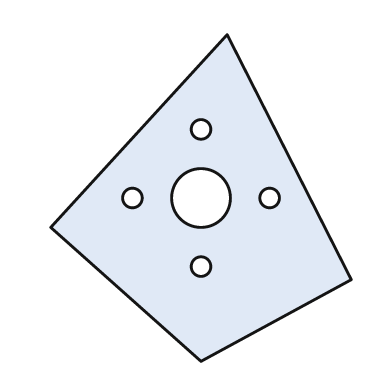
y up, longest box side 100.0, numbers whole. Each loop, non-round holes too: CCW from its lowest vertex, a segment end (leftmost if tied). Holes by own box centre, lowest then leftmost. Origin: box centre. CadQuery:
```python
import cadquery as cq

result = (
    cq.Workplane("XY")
    .moveTo(0.0, -50.0)
    .lineTo(46.0, -25.0)
    .lineTo(8.0, 50.0)
    .lineTo(-46.0, -9.0)
    .close()
    .moveTo(0.0, -21.0)
    .circle(3.0)
    .moveTo(-21.0, 0.0)
    .circle(3.0)
    .moveTo(0.0, 0.0)
    .circle(9.0)
    .moveTo(21.0, 0.0)
    .circle(3.0)
    .moveTo(0.0, 21.0)
    .circle(3.0)
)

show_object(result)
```